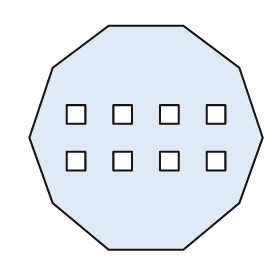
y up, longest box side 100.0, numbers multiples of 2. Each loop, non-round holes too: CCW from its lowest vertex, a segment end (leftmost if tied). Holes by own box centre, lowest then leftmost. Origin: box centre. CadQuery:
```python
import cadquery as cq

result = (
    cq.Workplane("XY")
    .moveTo(-16.0, -48.0)
    .lineTo(16.0, -48.0)
    .lineTo(40.0, -28.0)
    .lineTo(50.0, 0.0)
    .lineTo(40.0, 30.0)
    .lineTo(16.0, 48.0)
    .lineTo(-16.0, 48.0)
    .lineTo(-40.0, 30.0)
    .lineTo(-50.0, 0.0)
    .lineTo(-40.0, -28.0)
    .close()
    .moveTo(-34.0, -14.0)
    .lineTo(-26.0, -14.0)
    .lineTo(-26.0, -6.0)
    .lineTo(-34.0, -6.0)
    .close()
    .moveTo(-14.0, -14.0)
    .lineTo(-6.0, -14.0)
    .lineTo(-6.0, -6.0)
    .lineTo(-14.0, -6.0)
    .close()
    .moveTo(6.0, -14.0)
    .lineTo(14.0, -14.0)
    .lineTo(14.0, -6.0)
    .lineTo(6.0, -6.0)
    .close()
    .moveTo(26.0, -14.0)
    .lineTo(34.0, -14.0)
    .lineTo(34.0, -6.0)
    .lineTo(26.0, -6.0)
    .close()
    .moveTo(-34.0, 6.0)
    .lineTo(-26.0, 6.0)
    .lineTo(-26.0, 14.0)
    .lineTo(-34.0, 14.0)
    .close()
    .moveTo(-14.0, 6.0)
    .lineTo(-6.0, 6.0)
    .lineTo(-6.0, 14.0)
    .lineTo(-14.0, 14.0)
    .close()
    .moveTo(6.0, 6.0)
    .lineTo(14.0, 6.0)
    .lineTo(14.0, 14.0)
    .lineTo(6.0, 14.0)
    .close()
    .moveTo(26.0, 6.0)
    .lineTo(34.0, 6.0)
    .lineTo(34.0, 14.0)
    .lineTo(26.0, 14.0)
    .close()
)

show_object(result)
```